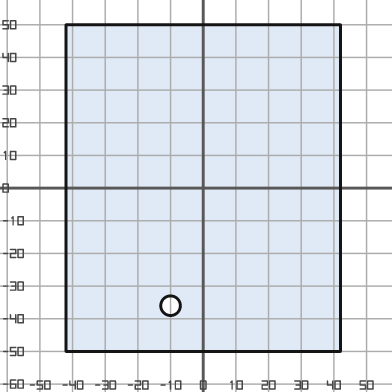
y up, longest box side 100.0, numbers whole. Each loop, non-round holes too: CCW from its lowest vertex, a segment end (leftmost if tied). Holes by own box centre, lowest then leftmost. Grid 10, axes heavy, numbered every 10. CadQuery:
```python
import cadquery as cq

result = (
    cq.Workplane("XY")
    .moveTo(-42.0, -50.0)
    .lineTo(42.0, -50.0)
    .lineTo(42.0, 50.0)
    .lineTo(-42.0, 50.0)
    .close()
    .moveTo(-10.0, -36.0)
    .circle(3.0)
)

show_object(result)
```